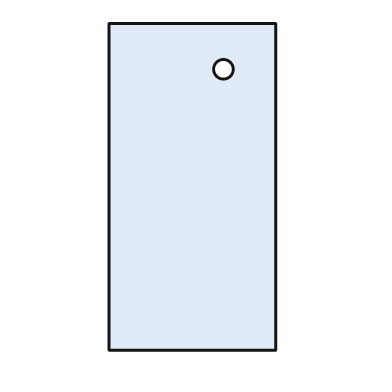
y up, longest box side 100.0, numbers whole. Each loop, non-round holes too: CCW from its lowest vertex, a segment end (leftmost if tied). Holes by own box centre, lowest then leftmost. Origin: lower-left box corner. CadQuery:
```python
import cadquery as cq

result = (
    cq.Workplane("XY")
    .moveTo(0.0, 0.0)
    .lineTo(51.0, 0.0)
    .lineTo(51.0, 100.0)
    .lineTo(0.0, 100.0)
    .close()
    .moveTo(35.0, 86.0)
    .circle(3.0)
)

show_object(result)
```